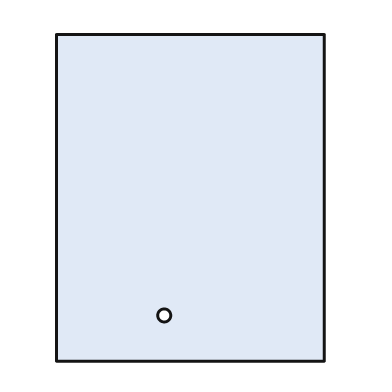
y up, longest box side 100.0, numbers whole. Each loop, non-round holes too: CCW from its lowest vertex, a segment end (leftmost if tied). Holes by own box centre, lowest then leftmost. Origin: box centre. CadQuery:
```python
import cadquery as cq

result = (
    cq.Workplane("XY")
    .moveTo(-41.0, -50.0)
    .lineTo(41.0, -50.0)
    .lineTo(41.0, 50.0)
    .lineTo(-41.0, 50.0)
    .close()
    .moveTo(-8.0, -36.0)
    .circle(2.0)
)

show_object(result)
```